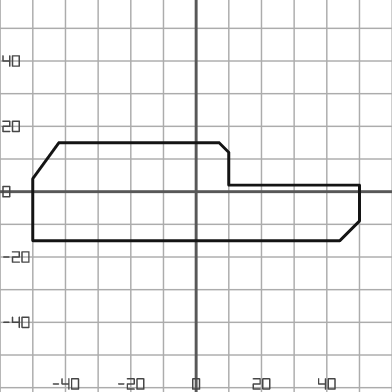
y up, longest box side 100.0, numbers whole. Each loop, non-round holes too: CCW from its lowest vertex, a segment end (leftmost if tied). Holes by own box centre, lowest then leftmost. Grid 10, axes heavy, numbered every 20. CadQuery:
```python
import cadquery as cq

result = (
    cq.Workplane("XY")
    .moveTo(-50.0, -15.0)
    .lineTo(44.0, -15.0)
    .lineTo(50.0, -9.0)
    .lineTo(50.0, 2.0)
    .lineTo(10.0, 2.0)
    .lineTo(10.0, 12.0)
    .lineTo(7.0, 15.0)
    .lineTo(-42.0, 15.0)
    .lineTo(-50.0, 4.0)
    .close()
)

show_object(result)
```